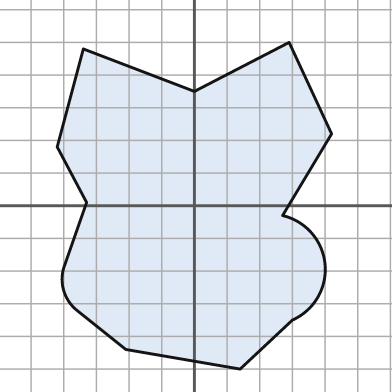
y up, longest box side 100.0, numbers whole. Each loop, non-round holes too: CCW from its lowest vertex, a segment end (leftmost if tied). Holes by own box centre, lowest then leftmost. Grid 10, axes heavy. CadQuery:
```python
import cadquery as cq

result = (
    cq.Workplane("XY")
    .moveTo(14.0, -50.0)
    .lineTo(30.0, -35.0)
    .threePointArc((40.0, -18.0), (27.0, -3.0))
    .lineTo(42.0, 22.0)
    .lineTo(29.0, 50.0)
    .lineTo(0.0, 35.0)
    .lineTo(-34.0, 48.0)
    .lineTo(-42.0, 18.0)
    .lineTo(-33.0, 1.0)
    .lineTo(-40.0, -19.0)
    .threePointArc((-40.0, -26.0), (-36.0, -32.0))
    .lineTo(-21.0, -44.0)
    .close()
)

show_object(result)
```